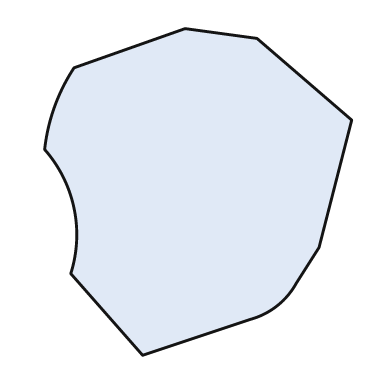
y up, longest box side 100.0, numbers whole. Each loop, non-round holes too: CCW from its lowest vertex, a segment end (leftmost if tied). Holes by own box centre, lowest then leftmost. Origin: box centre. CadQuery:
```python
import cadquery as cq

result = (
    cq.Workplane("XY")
    .moveTo(-17.0, -50.0)
    .lineTo(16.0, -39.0)
    .threePointArc((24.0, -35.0), (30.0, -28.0))
    .lineTo(37.0, -17.0)
    .lineTo(47.0, 22.0)
    .lineTo(18.0, 47.0)
    .lineTo(-4.0, 50.0)
    .lineTo(-38.0, 38.0)
    .threePointArc((-44.0, 26.0), (-47.0, 13.0))
    .threePointArc((-38.0, -5.0), (-39.0, -25.0))
    .close()
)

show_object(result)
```